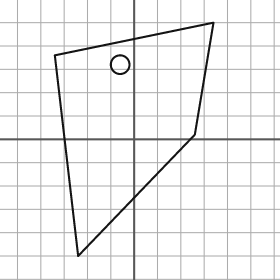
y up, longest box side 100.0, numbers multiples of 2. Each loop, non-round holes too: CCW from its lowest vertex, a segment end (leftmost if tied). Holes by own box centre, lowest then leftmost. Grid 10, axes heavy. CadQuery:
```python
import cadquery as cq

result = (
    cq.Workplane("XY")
    .moveTo(-24.0, -50.0)
    .lineTo(26.0, 2.0)
    .lineTo(34.0, 50.0)
    .lineTo(-34.0, 36.0)
    .close()
    .moveTo(-6.0, 32.0)
    .circle(4.0)
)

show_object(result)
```